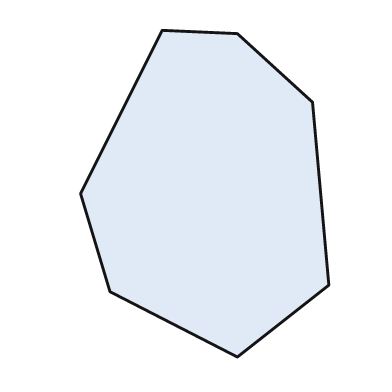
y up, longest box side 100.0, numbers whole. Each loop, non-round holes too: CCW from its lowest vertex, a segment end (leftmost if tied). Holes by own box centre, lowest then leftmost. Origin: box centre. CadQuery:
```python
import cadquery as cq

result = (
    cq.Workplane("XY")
    .moveTo(10.0, -50.0)
    .lineTo(38.0, -28.0)
    .lineTo(33.0, 28.0)
    .lineTo(10.0, 49.0)
    .lineTo(-13.0, 50.0)
    .lineTo(-38.0, 0.0)
    .lineTo(-29.0, -30.0)
    .close()
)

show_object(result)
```